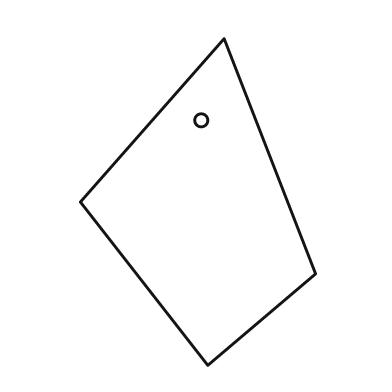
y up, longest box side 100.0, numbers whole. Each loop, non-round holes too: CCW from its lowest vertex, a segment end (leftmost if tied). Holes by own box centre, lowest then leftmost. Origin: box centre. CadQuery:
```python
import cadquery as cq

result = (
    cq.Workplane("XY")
    .moveTo(3.0, -50.0)
    .lineTo(36.0, -22.0)
    .lineTo(8.0, 50.0)
    .lineTo(-36.0, 0.0)
    .close()
    .moveTo(1.0, 25.0)
    .circle(2.0)
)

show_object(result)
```